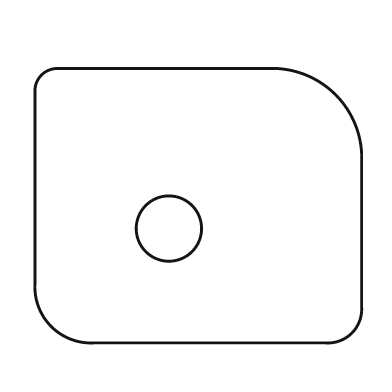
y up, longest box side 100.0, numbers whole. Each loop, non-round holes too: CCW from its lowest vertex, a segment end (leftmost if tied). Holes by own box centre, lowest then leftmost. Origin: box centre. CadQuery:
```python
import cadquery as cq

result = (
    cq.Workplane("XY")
    .moveTo(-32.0, -42.0)
    .lineTo(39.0, -42.0)
    .threePointArc((47.0, -39.0), (50.0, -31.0))
    .lineTo(50.0, 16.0)
    .threePointArc((42.0, 34.0), (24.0, 42.0))
    .lineTo(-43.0, 42.0)
    .threePointArc((-48.0, 40.0), (-50.0, 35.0))
    .lineTo(-50.0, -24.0)
    .threePointArc((-45.0, -37.0), (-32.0, -42.0))
    .close()
    .moveTo(-9.0, -7.0)
    .circle(10.0)
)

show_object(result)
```